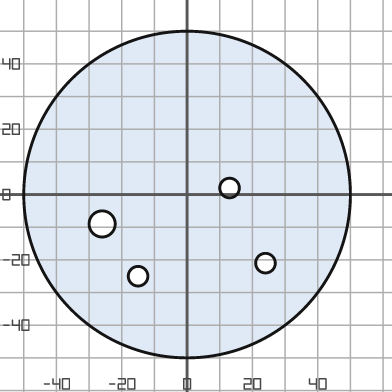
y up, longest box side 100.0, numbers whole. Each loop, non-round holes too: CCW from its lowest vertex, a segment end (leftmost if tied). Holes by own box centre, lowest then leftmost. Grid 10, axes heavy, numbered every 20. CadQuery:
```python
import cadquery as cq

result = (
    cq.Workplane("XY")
    .moveTo(0.0, 0.0)
    .circle(50.0)
    .moveTo(-15.0, -25.0)
    .circle(3.0)
    .moveTo(24.0, -21.0)
    .circle(3.0)
    .moveTo(-26.0, -9.0)
    .circle(4.0)
    .moveTo(13.0, 2.0)
    .circle(3.0)
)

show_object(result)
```